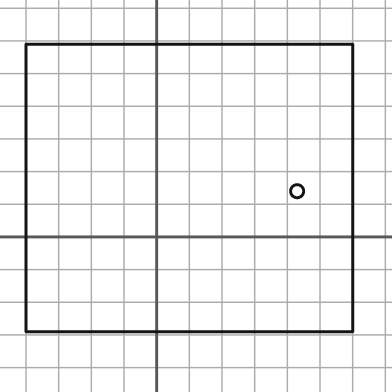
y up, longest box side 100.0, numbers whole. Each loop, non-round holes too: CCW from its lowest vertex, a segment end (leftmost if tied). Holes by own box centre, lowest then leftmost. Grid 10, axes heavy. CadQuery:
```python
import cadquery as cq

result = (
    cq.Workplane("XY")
    .moveTo(-40.0, -29.0)
    .lineTo(60.0, -29.0)
    .lineTo(60.0, 59.0)
    .lineTo(-40.0, 59.0)
    .close()
    .moveTo(43.0, 14.0)
    .circle(2.0)
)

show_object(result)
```